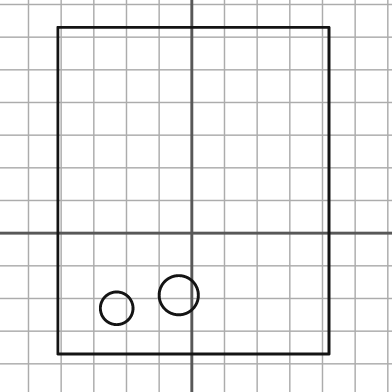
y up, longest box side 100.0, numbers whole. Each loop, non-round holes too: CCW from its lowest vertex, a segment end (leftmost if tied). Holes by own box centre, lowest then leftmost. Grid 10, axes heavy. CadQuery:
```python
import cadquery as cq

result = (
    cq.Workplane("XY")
    .moveTo(-41.0, -37.0)
    .lineTo(42.0, -37.0)
    .lineTo(42.0, 63.0)
    .lineTo(-41.0, 63.0)
    .close()
    .moveTo(-23.0, -23.0)
    .circle(5.0)
    .moveTo(-4.0, -19.0)
    .circle(6.0)
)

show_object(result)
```